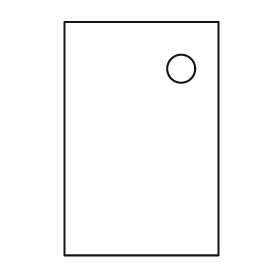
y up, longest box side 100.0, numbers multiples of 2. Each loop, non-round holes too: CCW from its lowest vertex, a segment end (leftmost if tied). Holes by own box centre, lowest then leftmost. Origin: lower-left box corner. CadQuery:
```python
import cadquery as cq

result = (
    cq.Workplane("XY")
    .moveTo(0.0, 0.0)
    .lineTo(66.0, 0.0)
    .lineTo(66.0, 100.0)
    .lineTo(0.0, 100.0)
    .close()
    .moveTo(50.0, 80.0)
    .circle(6.0)
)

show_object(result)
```